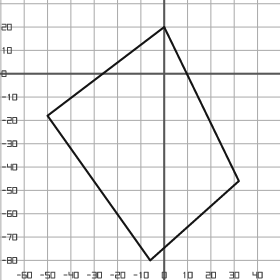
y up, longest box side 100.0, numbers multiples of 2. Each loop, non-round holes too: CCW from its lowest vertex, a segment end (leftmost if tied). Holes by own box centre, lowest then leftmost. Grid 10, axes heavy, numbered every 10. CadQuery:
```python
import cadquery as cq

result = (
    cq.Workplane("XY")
    .moveTo(-6.0, -80.0)
    .lineTo(32.0, -46.0)
    .lineTo(0.0, 20.0)
    .lineTo(-50.0, -18.0)
    .close()
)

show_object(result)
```